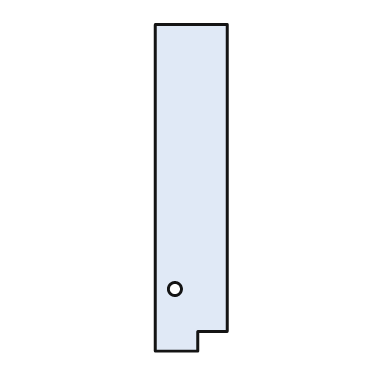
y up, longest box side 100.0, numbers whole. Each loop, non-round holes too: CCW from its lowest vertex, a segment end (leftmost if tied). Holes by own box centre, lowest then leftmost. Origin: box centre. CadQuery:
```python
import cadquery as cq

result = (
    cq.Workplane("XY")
    .moveTo(-11.0, -50.0)
    .lineTo(2.0, -50.0)
    .lineTo(2.0, -44.0)
    .lineTo(11.0, -44.0)
    .lineTo(11.0, 50.0)
    .lineTo(-11.0, 50.0)
    .close()
    .moveTo(-5.0, -31.0)
    .circle(2.0)
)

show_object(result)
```